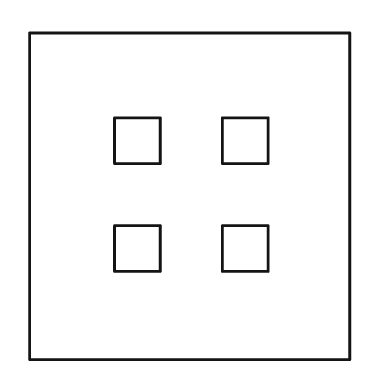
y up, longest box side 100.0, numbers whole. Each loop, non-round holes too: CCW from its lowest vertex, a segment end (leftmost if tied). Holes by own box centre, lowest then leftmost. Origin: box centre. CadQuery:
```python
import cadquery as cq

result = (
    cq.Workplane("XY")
    .moveTo(-49.0, -50.0)
    .lineTo(49.0, -50.0)
    .lineTo(49.0, 50.0)
    .lineTo(-49.0, 50.0)
    .close()
    .moveTo(-23.0, -23.0)
    .lineTo(-9.0, -23.0)
    .lineTo(-9.0, -9.0)
    .lineTo(-23.0, -9.0)
    .close()
    .moveTo(10.0, -23.0)
    .lineTo(24.0, -23.0)
    .lineTo(24.0, -9.0)
    .lineTo(10.0, -9.0)
    .close()
    .moveTo(-23.0, 10.0)
    .lineTo(-9.0, 10.0)
    .lineTo(-9.0, 24.0)
    .lineTo(-23.0, 24.0)
    .close()
    .moveTo(10.0, 10.0)
    .lineTo(24.0, 10.0)
    .lineTo(24.0, 24.0)
    .lineTo(10.0, 24.0)
    .close()
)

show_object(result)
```